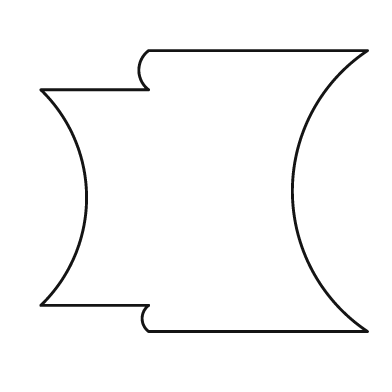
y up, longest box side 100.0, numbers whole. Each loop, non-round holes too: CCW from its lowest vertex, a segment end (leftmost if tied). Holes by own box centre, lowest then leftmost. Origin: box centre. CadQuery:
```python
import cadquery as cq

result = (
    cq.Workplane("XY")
    .moveTo(-17.0, -43.0)
    .lineTo(50.0, -43.0)
    .threePointArc((27.0, 0.0), (50.0, 43.0))
    .lineTo(-17.0, 43.0)
    .threePointArc((-20.0, 37.0), (-17.0, 31.0))
    .lineTo(-50.0, 31.0)
    .threePointArc((-36.0, -2.0), (-50.0, -35.0))
    .lineTo(-17.0, -35.0)
    .threePointArc((-19.0, -39.0), (-17.0, -43.0))
    .close()
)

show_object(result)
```